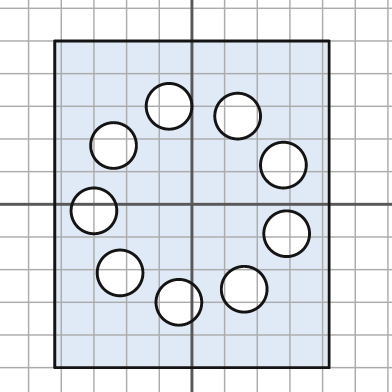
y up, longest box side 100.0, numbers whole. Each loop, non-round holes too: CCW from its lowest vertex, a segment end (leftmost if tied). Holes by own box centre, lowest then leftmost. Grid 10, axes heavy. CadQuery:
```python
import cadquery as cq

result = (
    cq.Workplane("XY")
    .moveTo(-42.0, -50.0)
    .lineTo(42.0, -50.0)
    .lineTo(42.0, 50.0)
    .lineTo(-42.0, 50.0)
    .close()
    .moveTo(-4.0, -30.0)
    .circle(7.0)
    .moveTo(16.0, -26.0)
    .circle(7.0)
    .moveTo(-22.0, -21.0)
    .circle(7.0)
    .moveTo(29.0, -9.0)
    .circle(7.0)
    .moveTo(-30.0, -2.0)
    .circle(7.0)
    .moveTo(28.0, 12.0)
    .circle(7.0)
    .moveTo(-24.0, 18.0)
    .circle(7.0)
    .moveTo(14.0, 27.0)
    .circle(7.0)
    .moveTo(-7.0, 30.0)
    .circle(7.0)
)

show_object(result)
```